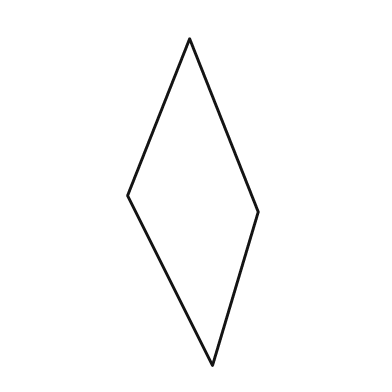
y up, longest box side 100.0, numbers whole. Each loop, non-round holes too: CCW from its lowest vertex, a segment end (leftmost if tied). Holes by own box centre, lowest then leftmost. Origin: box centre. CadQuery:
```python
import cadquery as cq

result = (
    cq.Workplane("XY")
    .moveTo(6.0, -50.0)
    .lineTo(20.0, -3.0)
    .lineTo(-1.0, 50.0)
    .lineTo(-20.0, 2.0)
    .close()
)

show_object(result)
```